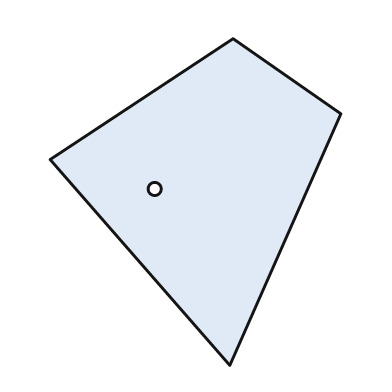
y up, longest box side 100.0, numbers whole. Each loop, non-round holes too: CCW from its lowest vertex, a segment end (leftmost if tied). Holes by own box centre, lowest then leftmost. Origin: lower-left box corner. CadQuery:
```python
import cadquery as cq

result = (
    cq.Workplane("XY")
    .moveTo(55.0, 0.0)
    .lineTo(89.0, 77.0)
    .lineTo(56.0, 100.0)
    .lineTo(0.0, 63.0)
    .close()
    .moveTo(32.0, 54.0)
    .circle(2.0)
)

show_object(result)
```